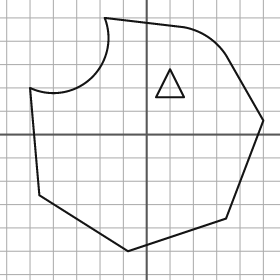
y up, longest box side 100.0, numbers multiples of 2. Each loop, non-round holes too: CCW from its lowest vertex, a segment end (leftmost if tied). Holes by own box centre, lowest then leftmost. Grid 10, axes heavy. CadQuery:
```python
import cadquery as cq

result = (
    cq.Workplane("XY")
    .moveTo(-8.0, -50.0)
    .lineTo(34.0, -36.0)
    .lineTo(50.0, 6.0)
    .lineTo(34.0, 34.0)
    .threePointArc((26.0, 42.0), (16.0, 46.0))
    .lineTo(-18.0, 50.0)
    .threePointArc((-24.0, 24.0), (-50.0, 20.0))
    .lineTo(-46.0, -26.0)
    .close()
    .moveTo(4.0, 16.0)
    .lineTo(16.0, 16.0)
    .lineTo(10.0, 28.0)
    .close()
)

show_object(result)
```